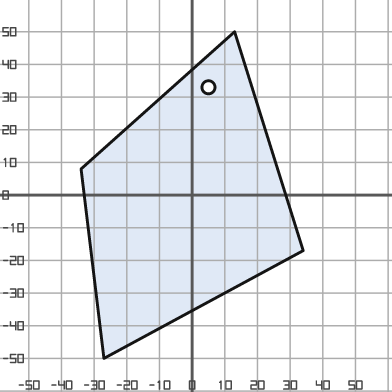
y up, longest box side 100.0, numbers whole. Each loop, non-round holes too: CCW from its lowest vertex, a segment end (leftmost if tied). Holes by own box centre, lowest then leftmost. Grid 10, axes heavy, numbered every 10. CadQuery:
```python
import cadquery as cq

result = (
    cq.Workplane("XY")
    .moveTo(-27.0, -50.0)
    .lineTo(34.0, -17.0)
    .lineTo(13.0, 50.0)
    .lineTo(-34.0, 8.0)
    .close()
    .moveTo(5.0, 33.0)
    .circle(2.0)
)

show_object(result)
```